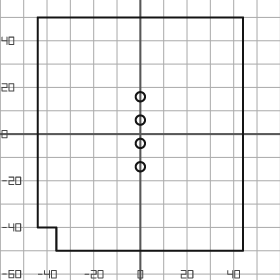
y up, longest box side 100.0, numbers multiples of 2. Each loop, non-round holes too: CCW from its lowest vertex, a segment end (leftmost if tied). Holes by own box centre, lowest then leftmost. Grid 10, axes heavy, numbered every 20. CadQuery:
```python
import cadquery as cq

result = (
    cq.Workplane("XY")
    .moveTo(-36.0, -50.0)
    .lineTo(44.0, -50.0)
    .lineTo(44.0, 50.0)
    .lineTo(-44.0, 50.0)
    .lineTo(-44.0, -40.0)
    .lineTo(-36.0, -40.0)
    .close()
    .moveTo(0.0, -14.0)
    .circle(2.0)
    .moveTo(0.0, -4.0)
    .circle(2.0)
    .moveTo(0.0, 6.0)
    .circle(2.0)
    .moveTo(0.0, 16.0)
    .circle(2.0)
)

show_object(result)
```